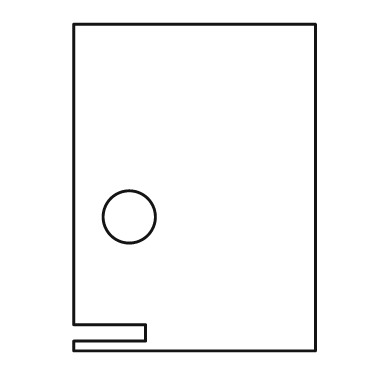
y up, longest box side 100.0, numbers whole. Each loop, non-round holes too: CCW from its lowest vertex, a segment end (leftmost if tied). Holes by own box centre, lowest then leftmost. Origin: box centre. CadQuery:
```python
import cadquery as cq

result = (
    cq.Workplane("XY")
    .moveTo(-37.0, -50.0)
    .lineTo(37.0, -50.0)
    .lineTo(37.0, 50.0)
    .lineTo(-37.0, 50.0)
    .lineTo(-37.0, -42.0)
    .lineTo(-15.0, -42.0)
    .lineTo(-15.0, -47.0)
    .lineTo(-37.0, -47.0)
    .close()
    .moveTo(-20.0, -9.0)
    .circle(8.0)
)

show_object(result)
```